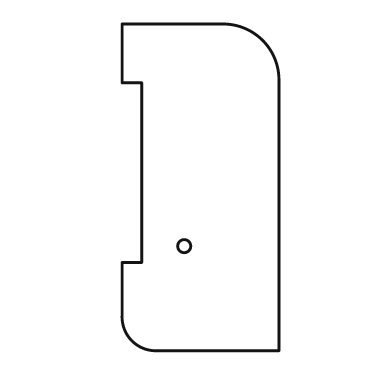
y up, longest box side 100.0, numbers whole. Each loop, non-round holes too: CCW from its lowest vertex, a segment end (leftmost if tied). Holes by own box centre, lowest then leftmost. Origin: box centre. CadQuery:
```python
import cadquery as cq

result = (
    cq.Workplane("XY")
    .moveTo(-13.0, -50.0)
    .lineTo(24.0, -50.0)
    .lineTo(24.0, 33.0)
    .threePointArc((19.0, 45.0), (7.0, 50.0))
    .lineTo(-24.0, 50.0)
    .lineTo(-24.0, 32.0)
    .lineTo(-18.0, 32.0)
    .lineTo(-18.0, -23.0)
    .lineTo(-24.0, -23.0)
    .lineTo(-24.0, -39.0)
    .threePointArc((-21.0, -47.0), (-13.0, -50.0))
    .close()
    .moveTo(-5.0, -18.0)
    .circle(2.0)
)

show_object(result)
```